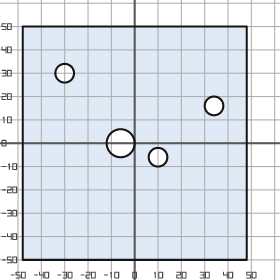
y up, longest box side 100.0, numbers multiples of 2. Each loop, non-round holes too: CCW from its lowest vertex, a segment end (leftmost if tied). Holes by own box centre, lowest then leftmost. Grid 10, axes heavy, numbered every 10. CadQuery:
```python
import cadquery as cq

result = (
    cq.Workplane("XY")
    .moveTo(-48.0, -50.0)
    .lineTo(48.0, -50.0)
    .lineTo(48.0, 50.0)
    .lineTo(-48.0, 50.0)
    .close()
    .moveTo(10.0, -6.0)
    .circle(4.0)
    .moveTo(-6.0, 0.0)
    .circle(6.0)
    .moveTo(34.0, 16.0)
    .circle(4.0)
    .moveTo(-30.0, 30.0)
    .circle(4.0)
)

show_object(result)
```